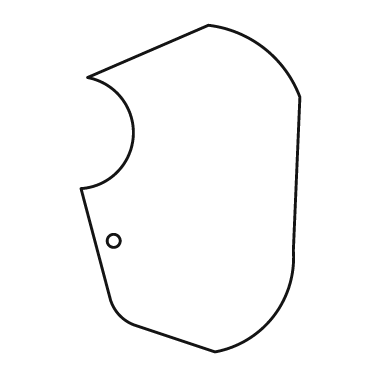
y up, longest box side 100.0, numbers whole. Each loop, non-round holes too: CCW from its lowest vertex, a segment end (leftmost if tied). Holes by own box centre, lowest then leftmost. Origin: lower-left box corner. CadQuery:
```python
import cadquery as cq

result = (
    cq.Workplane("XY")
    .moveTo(41.0, 0.0)
    .threePointArc((59.0, 11.0), (65.0, 31.0))
    .lineTo(67.0, 78.0)
    .threePointArc((56.0, 93.0), (39.0, 100.0))
    .lineTo(2.0, 84.0)
    .threePointArc((16.0, 66.0), (0.0, 50.0))
    .lineTo(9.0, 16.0)
    .threePointArc((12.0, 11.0), (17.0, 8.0))
    .close()
    .moveTo(10.0, 34.0)
    .circle(2.0)
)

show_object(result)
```